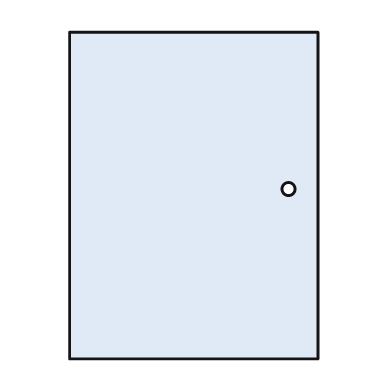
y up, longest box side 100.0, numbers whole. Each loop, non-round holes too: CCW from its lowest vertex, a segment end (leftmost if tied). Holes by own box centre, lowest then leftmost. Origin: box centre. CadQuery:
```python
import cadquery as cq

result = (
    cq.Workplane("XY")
    .moveTo(-38.0, -50.0)
    .lineTo(38.0, -50.0)
    .lineTo(38.0, 50.0)
    .lineTo(-38.0, 50.0)
    .close()
    .moveTo(29.0, 2.0)
    .circle(2.0)
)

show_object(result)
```